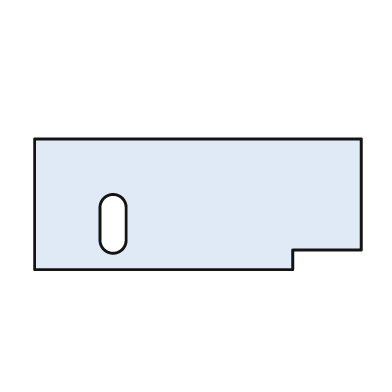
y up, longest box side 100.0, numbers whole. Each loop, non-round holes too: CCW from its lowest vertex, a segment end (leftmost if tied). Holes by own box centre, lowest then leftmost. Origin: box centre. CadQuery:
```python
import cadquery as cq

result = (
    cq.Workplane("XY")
    .moveTo(-50.0, -20.0)
    .lineTo(29.0, -20.0)
    .lineTo(29.0, -14.0)
    .lineTo(50.0, -14.0)
    .lineTo(50.0, 20.0)
    .lineTo(-50.0, 20.0)
    .close()
    .moveTo(-30.0, -11.0)
    .threePointArc((-26.0, -15.0), (-22.0, -11.0))
    .lineTo(-22.0, -1.0)
    .threePointArc((-26.0, 3.0), (-30.0, -1.0))
    .close()
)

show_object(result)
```